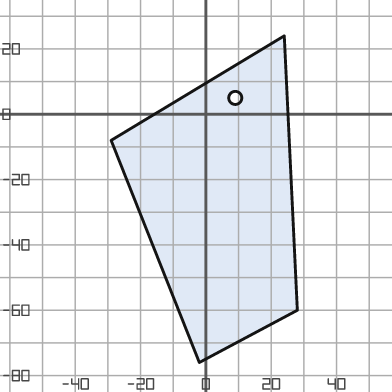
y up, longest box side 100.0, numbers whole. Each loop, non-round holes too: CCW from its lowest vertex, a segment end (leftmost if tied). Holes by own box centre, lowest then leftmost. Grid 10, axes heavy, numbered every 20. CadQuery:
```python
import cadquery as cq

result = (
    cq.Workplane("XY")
    .moveTo(-2.0, -76.0)
    .lineTo(28.0, -60.0)
    .lineTo(24.0, 24.0)
    .lineTo(-29.0, -8.0)
    .close()
    .moveTo(9.0, 5.0)
    .circle(2.0)
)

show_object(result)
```